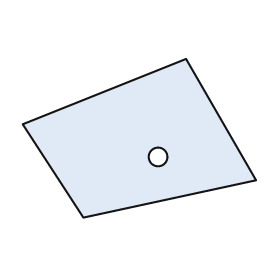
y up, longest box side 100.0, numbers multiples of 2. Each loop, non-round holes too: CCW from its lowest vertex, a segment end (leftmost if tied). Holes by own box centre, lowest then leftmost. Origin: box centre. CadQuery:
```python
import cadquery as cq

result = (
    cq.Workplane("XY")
    .moveTo(-24.0, -34.0)
    .lineTo(50.0, -18.0)
    .lineTo(20.0, 34.0)
    .lineTo(-50.0, 6.0)
    .close()
    .moveTo(8.0, -8.0)
    .circle(4.0)
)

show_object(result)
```